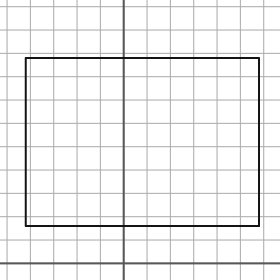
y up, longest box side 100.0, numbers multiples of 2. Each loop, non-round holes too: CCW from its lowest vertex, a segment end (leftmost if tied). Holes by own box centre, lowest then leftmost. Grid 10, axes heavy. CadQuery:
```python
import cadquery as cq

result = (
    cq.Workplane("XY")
    .moveTo(-42.0, 16.0)
    .lineTo(58.0, 16.0)
    .lineTo(58.0, 88.0)
    .lineTo(-42.0, 88.0)
    .close()
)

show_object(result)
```